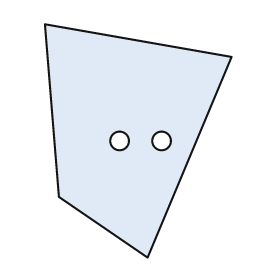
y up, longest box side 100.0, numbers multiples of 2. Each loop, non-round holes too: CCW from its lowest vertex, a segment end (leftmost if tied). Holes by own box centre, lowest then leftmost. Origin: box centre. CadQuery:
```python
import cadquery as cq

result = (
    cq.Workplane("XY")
    .moveTo(4.0, -50.0)
    .lineTo(40.0, 36.0)
    .lineTo(-40.0, 50.0)
    .lineTo(-34.0, -24.0)
    .close()
    .moveTo(-8.0, 0.0)
    .circle(4.0)
    .moveTo(10.0, 0.0)
    .circle(4.0)
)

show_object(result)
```